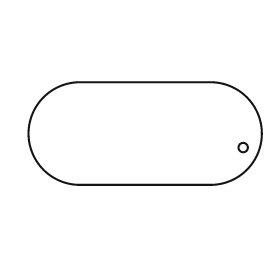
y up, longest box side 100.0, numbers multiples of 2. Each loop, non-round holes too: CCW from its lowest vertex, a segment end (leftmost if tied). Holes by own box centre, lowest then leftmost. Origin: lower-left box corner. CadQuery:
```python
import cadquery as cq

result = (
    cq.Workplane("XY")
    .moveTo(22.0, 0.0)
    .lineTo(78.0, 0.0)
    .threePointArc((100.0, 22.0), (78.0, 44.0))
    .lineTo(22.0, 44.0)
    .threePointArc((0.0, 22.0), (22.0, 0.0))
    .close()
    .moveTo(92.0, 16.0)
    .circle(2.0)
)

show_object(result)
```